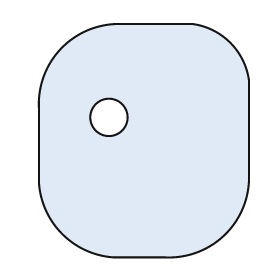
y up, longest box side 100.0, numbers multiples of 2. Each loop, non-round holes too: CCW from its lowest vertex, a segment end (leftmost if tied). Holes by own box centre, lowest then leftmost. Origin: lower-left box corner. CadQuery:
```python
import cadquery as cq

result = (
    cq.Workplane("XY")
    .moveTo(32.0, 0.0)
    .lineTo(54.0, 0.0)
    .threePointArc((80.0, 10.0), (90.0, 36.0))
    .lineTo(90.0, 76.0)
    .threePointArc((82.0, 92.0), (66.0, 100.0))
    .lineTo(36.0, 100.0)
    .threePointArc((10.0, 90.0), (0.0, 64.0))
    .lineTo(0.0, 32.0)
    .threePointArc((10.0, 10.0), (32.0, 0.0))
    .close()
    .moveTo(30.0, 60.0)
    .circle(8.0)
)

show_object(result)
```